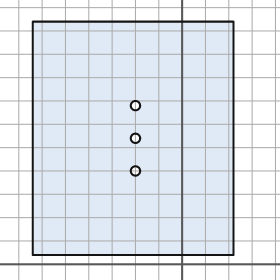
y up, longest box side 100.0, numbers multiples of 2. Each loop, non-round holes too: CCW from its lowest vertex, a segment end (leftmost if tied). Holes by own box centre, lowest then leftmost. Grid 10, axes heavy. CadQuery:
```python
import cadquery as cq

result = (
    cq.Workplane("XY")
    .moveTo(-64.0, 4.0)
    .lineTo(22.0, 4.0)
    .lineTo(22.0, 104.0)
    .lineTo(-64.0, 104.0)
    .close()
    .moveTo(-20.0, 40.0)
    .circle(2.0)
    .moveTo(-20.0, 54.0)
    .circle(2.0)
    .moveTo(-20.0, 68.0)
    .circle(2.0)
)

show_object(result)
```